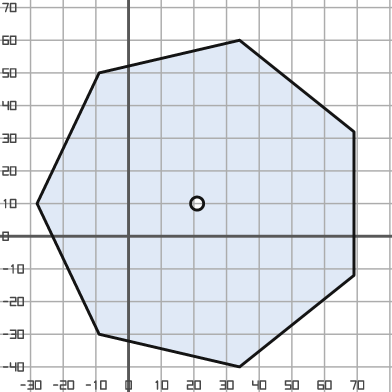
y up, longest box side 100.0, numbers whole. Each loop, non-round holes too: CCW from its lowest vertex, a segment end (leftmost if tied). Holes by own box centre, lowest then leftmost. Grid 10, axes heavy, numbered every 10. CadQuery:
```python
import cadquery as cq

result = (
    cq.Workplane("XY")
    .moveTo(34.0, -40.0)
    .lineTo(69.0, -12.0)
    .lineTo(69.0, 32.0)
    .lineTo(34.0, 60.0)
    .lineTo(-9.0, 50.0)
    .lineTo(-28.0, 10.0)
    .lineTo(-9.0, -30.0)
    .close()
    .moveTo(21.0, 10.0)
    .circle(2.0)
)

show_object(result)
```